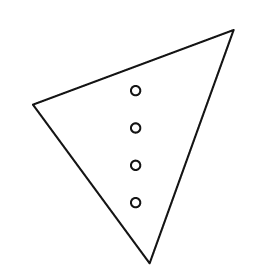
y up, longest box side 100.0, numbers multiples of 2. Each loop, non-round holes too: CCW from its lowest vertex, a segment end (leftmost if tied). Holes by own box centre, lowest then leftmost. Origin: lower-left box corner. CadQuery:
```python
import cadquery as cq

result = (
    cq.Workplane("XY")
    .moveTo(50.0, 0.0)
    .lineTo(86.0, 100.0)
    .lineTo(0.0, 68.0)
    .close()
    .moveTo(44.0, 26.0)
    .circle(2.0)
    .moveTo(44.0, 42.0)
    .circle(2.0)
    .moveTo(44.0, 58.0)
    .circle(2.0)
    .moveTo(44.0, 74.0)
    .circle(2.0)
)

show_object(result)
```